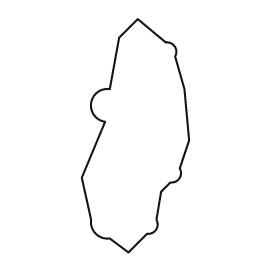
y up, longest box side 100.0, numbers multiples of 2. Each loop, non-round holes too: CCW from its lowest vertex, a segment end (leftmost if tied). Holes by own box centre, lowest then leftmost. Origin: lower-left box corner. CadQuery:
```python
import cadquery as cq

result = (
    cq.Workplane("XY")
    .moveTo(20.0, 0.0)
    .lineTo(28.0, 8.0)
    .threePointArc((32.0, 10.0), (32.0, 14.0))
    .lineTo(34.0, 26.0)
    .lineTo(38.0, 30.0)
    .threePointArc((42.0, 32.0), (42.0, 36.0))
    .lineTo(46.0, 48.0)
    .lineTo(44.0, 70.0)
    .lineTo(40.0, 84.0)
    .threePointArc((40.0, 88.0), (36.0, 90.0))
    .lineTo(24.0, 100.0)
    .lineTo(16.0, 92.0)
    .lineTo(12.0, 70.0)
    .threePointArc((4.0, 64.0), (10.0, 56.0))
    .lineTo(0.0, 32.0)
    .lineTo(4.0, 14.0)
    .threePointArc((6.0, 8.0), (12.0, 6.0))
    .close()
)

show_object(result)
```